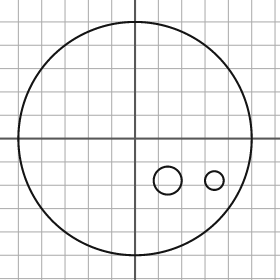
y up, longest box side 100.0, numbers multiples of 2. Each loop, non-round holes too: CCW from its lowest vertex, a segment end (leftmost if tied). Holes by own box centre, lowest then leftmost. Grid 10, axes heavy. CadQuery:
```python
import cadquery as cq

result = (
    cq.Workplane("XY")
    .moveTo(0.0, 0.0)
    .circle(50.0)
    .moveTo(14.0, -18.0)
    .circle(6.0)
    .moveTo(34.0, -18.0)
    .circle(4.0)
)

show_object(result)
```